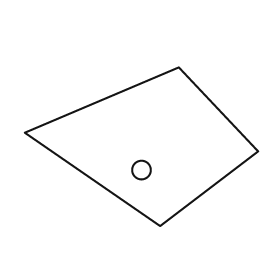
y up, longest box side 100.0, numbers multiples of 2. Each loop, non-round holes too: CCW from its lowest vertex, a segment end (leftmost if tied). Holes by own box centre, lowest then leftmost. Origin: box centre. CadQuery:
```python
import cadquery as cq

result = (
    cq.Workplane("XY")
    .moveTo(8.0, -34.0)
    .lineTo(50.0, -2.0)
    .lineTo(16.0, 34.0)
    .lineTo(-50.0, 6.0)
    .close()
    .moveTo(0.0, -10.0)
    .circle(4.0)
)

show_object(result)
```